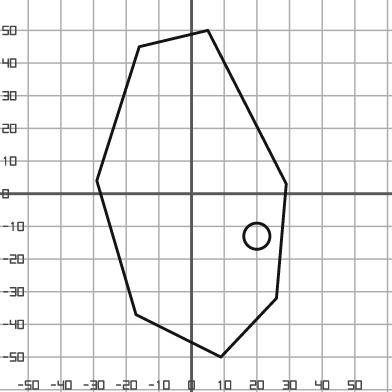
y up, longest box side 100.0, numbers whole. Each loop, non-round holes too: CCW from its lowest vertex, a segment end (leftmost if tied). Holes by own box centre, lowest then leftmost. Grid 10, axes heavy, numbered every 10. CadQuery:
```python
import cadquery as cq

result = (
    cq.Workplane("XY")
    .moveTo(9.0, -50.0)
    .lineTo(26.0, -32.0)
    .lineTo(29.0, 3.0)
    .lineTo(5.0, 50.0)
    .lineTo(-16.0, 45.0)
    .lineTo(-29.0, 4.0)
    .lineTo(-17.0, -37.0)
    .close()
    .moveTo(20.0, -13.0)
    .circle(4.0)
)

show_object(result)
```